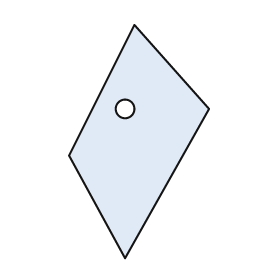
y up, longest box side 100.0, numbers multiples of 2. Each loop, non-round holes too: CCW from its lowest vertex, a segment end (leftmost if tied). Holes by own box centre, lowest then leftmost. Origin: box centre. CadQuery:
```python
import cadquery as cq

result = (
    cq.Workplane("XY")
    .moveTo(-6.0, -50.0)
    .lineTo(30.0, 14.0)
    .lineTo(-2.0, 50.0)
    .lineTo(-30.0, -6.0)
    .close()
    .moveTo(-6.0, 14.0)
    .circle(4.0)
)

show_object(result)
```